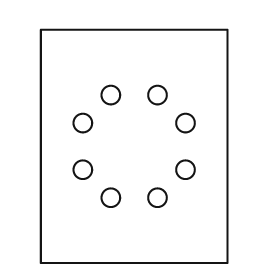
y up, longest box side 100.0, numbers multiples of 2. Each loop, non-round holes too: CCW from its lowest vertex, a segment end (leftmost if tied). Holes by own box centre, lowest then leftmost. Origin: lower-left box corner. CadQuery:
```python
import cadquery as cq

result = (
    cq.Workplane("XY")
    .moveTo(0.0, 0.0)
    .lineTo(80.0, 0.0)
    .lineTo(80.0, 100.0)
    .lineTo(0.0, 100.0)
    .close()
    .moveTo(30.0, 28.0)
    .circle(4.0)
    .moveTo(50.0, 28.0)
    .circle(4.0)
    .moveTo(18.0, 40.0)
    .circle(4.0)
    .moveTo(62.0, 40.0)
    .circle(4.0)
    .moveTo(18.0, 60.0)
    .circle(4.0)
    .moveTo(62.0, 60.0)
    .circle(4.0)
    .moveTo(30.0, 72.0)
    .circle(4.0)
    .moveTo(50.0, 72.0)
    .circle(4.0)
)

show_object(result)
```